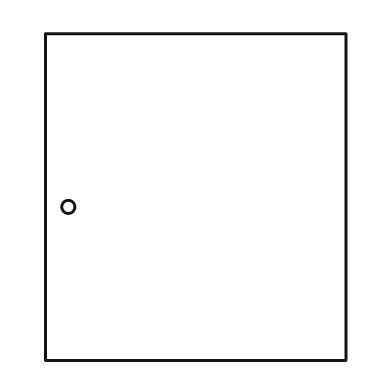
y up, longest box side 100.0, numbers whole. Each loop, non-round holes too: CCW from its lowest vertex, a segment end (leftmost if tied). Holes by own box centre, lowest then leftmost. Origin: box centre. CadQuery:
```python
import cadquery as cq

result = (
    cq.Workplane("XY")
    .moveTo(-46.0, -50.0)
    .lineTo(46.0, -50.0)
    .lineTo(46.0, 50.0)
    .lineTo(-46.0, 50.0)
    .close()
    .moveTo(-39.0, -3.0)
    .circle(2.0)
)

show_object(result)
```